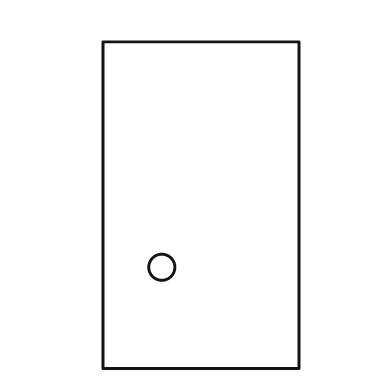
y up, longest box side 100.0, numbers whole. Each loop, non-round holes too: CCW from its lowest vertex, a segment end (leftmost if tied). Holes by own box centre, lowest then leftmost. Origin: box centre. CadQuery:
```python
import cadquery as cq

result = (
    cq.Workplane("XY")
    .moveTo(-30.0, -50.0)
    .lineTo(30.0, -50.0)
    .lineTo(30.0, 50.0)
    .lineTo(-30.0, 50.0)
    .close()
    .moveTo(-12.0, -19.0)
    .circle(4.0)
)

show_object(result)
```